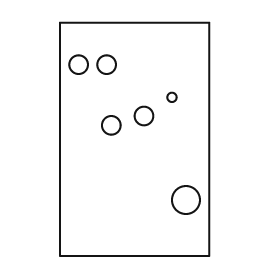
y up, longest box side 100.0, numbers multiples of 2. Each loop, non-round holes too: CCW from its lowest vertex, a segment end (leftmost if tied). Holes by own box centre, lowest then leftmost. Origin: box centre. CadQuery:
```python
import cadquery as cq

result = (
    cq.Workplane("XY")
    .moveTo(-32.0, -50.0)
    .lineTo(32.0, -50.0)
    .lineTo(32.0, 50.0)
    .lineTo(-32.0, 50.0)
    .close()
    .moveTo(22.0, -26.0)
    .circle(6.0)
    .moveTo(-10.0, 6.0)
    .circle(4.0)
    .moveTo(4.0, 10.0)
    .circle(4.0)
    .moveTo(16.0, 18.0)
    .circle(2.0)
    .moveTo(-24.0, 32.0)
    .circle(4.0)
    .moveTo(-12.0, 32.0)
    .circle(4.0)
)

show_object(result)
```